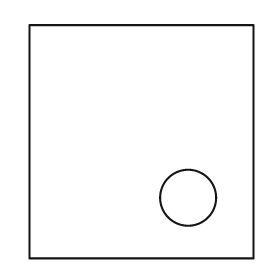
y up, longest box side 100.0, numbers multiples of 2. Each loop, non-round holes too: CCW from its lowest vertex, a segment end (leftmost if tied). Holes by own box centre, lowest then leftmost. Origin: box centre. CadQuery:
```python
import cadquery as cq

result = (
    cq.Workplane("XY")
    .moveTo(-48.0, -50.0)
    .lineTo(48.0, -50.0)
    .lineTo(48.0, 50.0)
    .lineTo(-48.0, 50.0)
    .close()
    .moveTo(20.0, -24.0)
    .circle(12.0)
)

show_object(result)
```